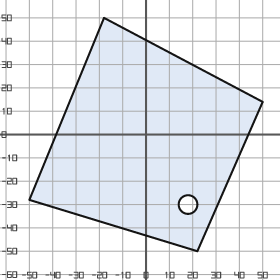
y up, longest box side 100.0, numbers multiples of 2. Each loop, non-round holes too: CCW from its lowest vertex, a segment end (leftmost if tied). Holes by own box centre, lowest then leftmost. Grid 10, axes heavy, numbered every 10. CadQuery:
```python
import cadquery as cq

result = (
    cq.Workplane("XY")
    .moveTo(22.0, -50.0)
    .lineTo(50.0, 14.0)
    .lineTo(-18.0, 50.0)
    .lineTo(-50.0, -28.0)
    .close()
    .moveTo(18.0, -30.0)
    .circle(4.0)
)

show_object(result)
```